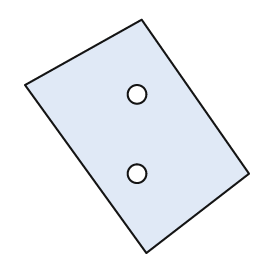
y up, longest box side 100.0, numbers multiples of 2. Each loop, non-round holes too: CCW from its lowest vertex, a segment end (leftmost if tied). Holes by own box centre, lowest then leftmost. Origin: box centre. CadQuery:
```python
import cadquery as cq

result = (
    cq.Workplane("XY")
    .moveTo(4.0, -50.0)
    .lineTo(48.0, -16.0)
    .lineTo(2.0, 50.0)
    .lineTo(-48.0, 22.0)
    .close()
    .moveTo(0.0, -16.0)
    .circle(4.0)
    .moveTo(0.0, 18.0)
    .circle(4.0)
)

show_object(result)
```